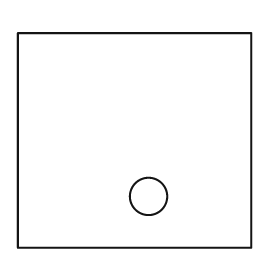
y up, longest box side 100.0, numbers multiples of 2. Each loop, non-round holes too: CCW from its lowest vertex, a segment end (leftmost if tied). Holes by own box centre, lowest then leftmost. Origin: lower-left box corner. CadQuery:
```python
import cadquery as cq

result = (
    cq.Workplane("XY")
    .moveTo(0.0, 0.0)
    .lineTo(100.0, 0.0)
    .lineTo(100.0, 92.0)
    .lineTo(0.0, 92.0)
    .close()
    .moveTo(56.0, 22.0)
    .circle(8.0)
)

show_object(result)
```